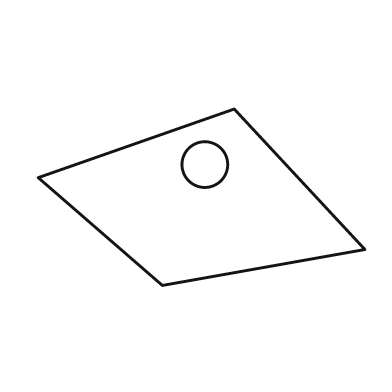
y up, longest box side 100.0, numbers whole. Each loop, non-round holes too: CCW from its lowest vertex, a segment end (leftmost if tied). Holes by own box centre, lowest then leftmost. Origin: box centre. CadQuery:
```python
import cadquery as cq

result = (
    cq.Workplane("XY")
    .moveTo(-12.0, -27.0)
    .lineTo(50.0, -16.0)
    .lineTo(10.0, 27.0)
    .lineTo(-50.0, 6.0)
    .close()
    .moveTo(1.0, 10.0)
    .circle(7.0)
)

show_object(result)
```